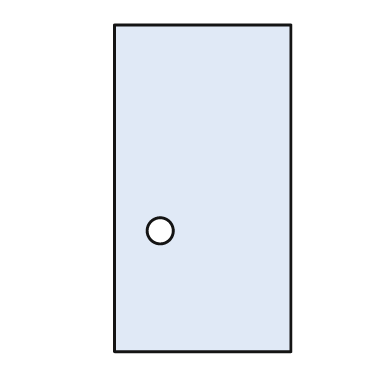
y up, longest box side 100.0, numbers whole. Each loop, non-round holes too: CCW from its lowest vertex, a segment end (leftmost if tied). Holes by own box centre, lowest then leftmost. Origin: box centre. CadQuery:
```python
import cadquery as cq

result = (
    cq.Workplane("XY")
    .moveTo(-27.0, -50.0)
    .lineTo(27.0, -50.0)
    .lineTo(27.0, 50.0)
    .lineTo(-27.0, 50.0)
    .close()
    .moveTo(-13.0, -13.0)
    .circle(4.0)
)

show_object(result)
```